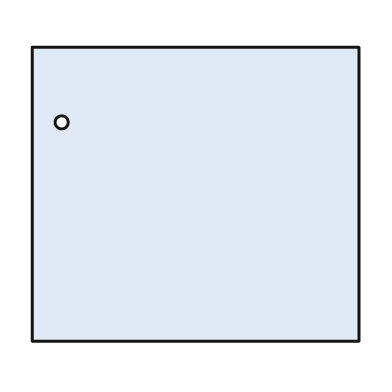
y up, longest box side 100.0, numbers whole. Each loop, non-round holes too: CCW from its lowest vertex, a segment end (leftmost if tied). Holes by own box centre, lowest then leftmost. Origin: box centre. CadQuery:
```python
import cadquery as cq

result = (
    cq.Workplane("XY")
    .moveTo(-50.0, -45.0)
    .lineTo(50.0, -45.0)
    .lineTo(50.0, 45.0)
    .lineTo(-50.0, 45.0)
    .close()
    .moveTo(-41.0, 22.0)
    .circle(2.0)
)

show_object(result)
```